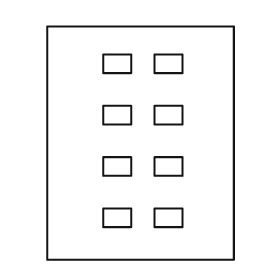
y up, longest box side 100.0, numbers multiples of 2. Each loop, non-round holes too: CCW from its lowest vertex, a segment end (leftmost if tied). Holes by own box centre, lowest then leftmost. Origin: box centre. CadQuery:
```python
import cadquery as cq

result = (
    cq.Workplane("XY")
    .moveTo(-40.0, -50.0)
    .lineTo(40.0, -50.0)
    .lineTo(40.0, 50.0)
    .lineTo(-40.0, 50.0)
    .close()
    .moveTo(-16.0, -36.0)
    .lineTo(-4.0, -36.0)
    .lineTo(-4.0, -28.0)
    .lineTo(-16.0, -28.0)
    .close()
    .moveTo(6.0, -36.0)
    .lineTo(18.0, -36.0)
    .lineTo(18.0, -28.0)
    .lineTo(6.0, -28.0)
    .close()
    .moveTo(-16.0, -14.0)
    .lineTo(-4.0, -14.0)
    .lineTo(-4.0, -6.0)
    .lineTo(-16.0, -6.0)
    .close()
    .moveTo(6.0, -14.0)
    .lineTo(18.0, -14.0)
    .lineTo(18.0, -6.0)
    .lineTo(6.0, -6.0)
    .close()
    .moveTo(-16.0, 8.0)
    .lineTo(-4.0, 8.0)
    .lineTo(-4.0, 16.0)
    .lineTo(-16.0, 16.0)
    .close()
    .moveTo(6.0, 8.0)
    .lineTo(18.0, 8.0)
    .lineTo(18.0, 16.0)
    .lineTo(6.0, 16.0)
    .close()
    .moveTo(-16.0, 30.0)
    .lineTo(-4.0, 30.0)
    .lineTo(-4.0, 38.0)
    .lineTo(-16.0, 38.0)
    .close()
    .moveTo(6.0, 30.0)
    .lineTo(18.0, 30.0)
    .lineTo(18.0, 38.0)
    .lineTo(6.0, 38.0)
    .close()
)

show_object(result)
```